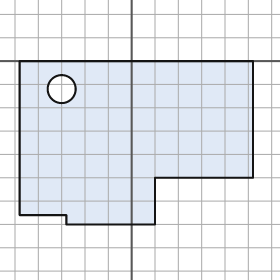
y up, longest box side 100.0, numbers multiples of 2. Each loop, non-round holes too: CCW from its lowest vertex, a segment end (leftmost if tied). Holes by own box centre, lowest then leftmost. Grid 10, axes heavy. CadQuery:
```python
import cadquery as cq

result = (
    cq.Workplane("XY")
    .moveTo(-28.0, -70.0)
    .lineTo(10.0, -70.0)
    .lineTo(10.0, -50.0)
    .lineTo(52.0, -50.0)
    .lineTo(52.0, 0.0)
    .lineTo(-48.0, 0.0)
    .lineTo(-48.0, -66.0)
    .lineTo(-28.0, -66.0)
    .close()
    .moveTo(-30.0, -12.0)
    .circle(6.0)
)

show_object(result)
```